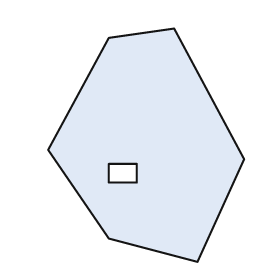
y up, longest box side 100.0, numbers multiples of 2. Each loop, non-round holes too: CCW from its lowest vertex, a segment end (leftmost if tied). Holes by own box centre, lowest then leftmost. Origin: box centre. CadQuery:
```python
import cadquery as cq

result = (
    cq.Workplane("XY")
    .moveTo(22.0, -50.0)
    .lineTo(42.0, -6.0)
    .lineTo(12.0, 50.0)
    .lineTo(-16.0, 46.0)
    .lineTo(-42.0, -2.0)
    .lineTo(-16.0, -40.0)
    .close()
    .moveTo(-16.0, -16.0)
    .lineTo(-4.0, -16.0)
    .lineTo(-4.0, -8.0)
    .lineTo(-16.0, -8.0)
    .close()
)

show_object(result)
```